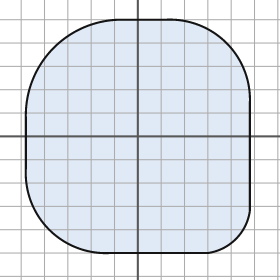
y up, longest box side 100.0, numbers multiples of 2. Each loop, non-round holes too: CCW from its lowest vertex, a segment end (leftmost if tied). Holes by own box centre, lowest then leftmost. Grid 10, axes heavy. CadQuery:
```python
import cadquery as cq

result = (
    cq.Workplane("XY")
    .moveTo(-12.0, -50.0)
    .lineTo(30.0, -50.0)
    .threePointArc((42.0, -44.0), (48.0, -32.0))
    .lineTo(48.0, 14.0)
    .threePointArc((38.0, 40.0), (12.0, 50.0))
    .lineTo(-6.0, 50.0)
    .threePointArc((-36.0, 38.0), (-48.0, 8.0))
    .lineTo(-48.0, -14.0)
    .threePointArc((-38.0, -40.0), (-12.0, -50.0))
    .close()
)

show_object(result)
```